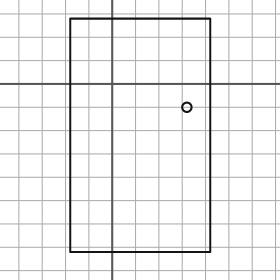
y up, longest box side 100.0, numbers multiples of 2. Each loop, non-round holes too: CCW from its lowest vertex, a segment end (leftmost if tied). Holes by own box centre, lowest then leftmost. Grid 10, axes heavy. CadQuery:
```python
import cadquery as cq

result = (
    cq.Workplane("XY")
    .moveTo(-18.0, -72.0)
    .lineTo(42.0, -72.0)
    .lineTo(42.0, 28.0)
    .lineTo(-18.0, 28.0)
    .close()
    .moveTo(32.0, -10.0)
    .circle(2.0)
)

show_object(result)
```